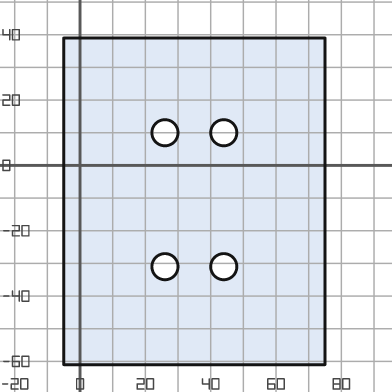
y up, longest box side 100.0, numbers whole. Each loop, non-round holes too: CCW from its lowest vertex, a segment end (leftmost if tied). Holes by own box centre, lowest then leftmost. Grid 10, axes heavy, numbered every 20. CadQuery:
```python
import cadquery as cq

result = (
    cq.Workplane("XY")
    .moveTo(-5.0, -61.0)
    .lineTo(75.0, -61.0)
    .lineTo(75.0, 39.0)
    .lineTo(-5.0, 39.0)
    .close()
    .moveTo(26.0, -31.0)
    .circle(4.0)
    .moveTo(44.0, -31.0)
    .circle(4.0)
    .moveTo(26.0, 10.0)
    .circle(4.0)
    .moveTo(44.0, 10.0)
    .circle(4.0)
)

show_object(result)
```